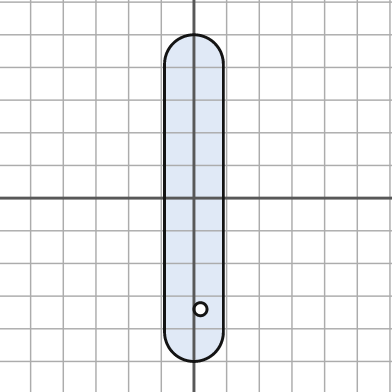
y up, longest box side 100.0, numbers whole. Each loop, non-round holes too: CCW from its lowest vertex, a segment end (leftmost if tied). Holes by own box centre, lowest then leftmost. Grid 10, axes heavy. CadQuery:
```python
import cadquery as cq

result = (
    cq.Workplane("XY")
    .moveTo(-9.0, -41.0)
    .threePointArc((0.0, -50.0), (9.0, -41.0))
    .lineTo(9.0, 41.0)
    .threePointArc((0.0, 50.0), (-9.0, 41.0))
    .close()
    .moveTo(2.0, -34.0)
    .circle(2.0)
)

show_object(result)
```